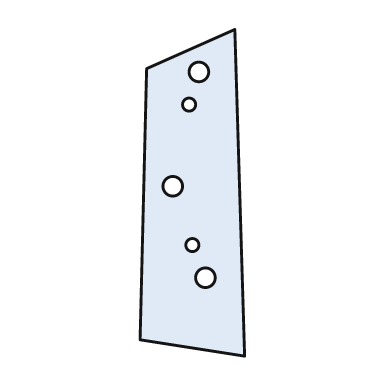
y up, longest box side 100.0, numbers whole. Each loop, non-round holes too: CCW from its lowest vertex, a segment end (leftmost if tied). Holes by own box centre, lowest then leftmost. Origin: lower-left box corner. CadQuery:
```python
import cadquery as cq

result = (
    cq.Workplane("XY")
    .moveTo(32.0, 0.0)
    .lineTo(29.0, 100.0)
    .lineTo(2.0, 88.0)
    .lineTo(0.0, 5.0)
    .close()
    .moveTo(20.0, 24.0)
    .circle(3.0)
    .moveTo(16.0, 34.0)
    .circle(2.0)
    .moveTo(10.0, 52.0)
    .circle(3.0)
    .moveTo(15.0, 77.0)
    .circle(2.0)
    .moveTo(18.0, 87.0)
    .circle(3.0)
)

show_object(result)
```